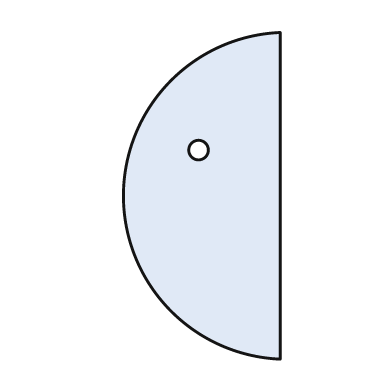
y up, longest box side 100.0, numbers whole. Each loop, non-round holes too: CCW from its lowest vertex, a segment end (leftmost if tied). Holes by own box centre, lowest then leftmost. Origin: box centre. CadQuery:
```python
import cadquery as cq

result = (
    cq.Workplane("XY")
    .moveTo(24.0, -50.0)
    .lineTo(24.0, 50.0)
    .threePointArc((-24.0, 0.0), (24.0, -50.0))
    .close()
    .moveTo(-1.0, 14.0)
    .circle(3.0)
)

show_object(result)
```